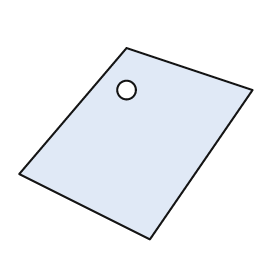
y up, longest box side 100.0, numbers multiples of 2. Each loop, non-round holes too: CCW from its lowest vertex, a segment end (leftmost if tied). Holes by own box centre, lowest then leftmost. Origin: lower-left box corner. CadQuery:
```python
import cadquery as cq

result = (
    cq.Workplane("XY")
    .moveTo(56.0, 0.0)
    .lineTo(100.0, 64.0)
    .lineTo(46.0, 82.0)
    .lineTo(0.0, 28.0)
    .close()
    .moveTo(46.0, 64.0)
    .circle(4.0)
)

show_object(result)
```